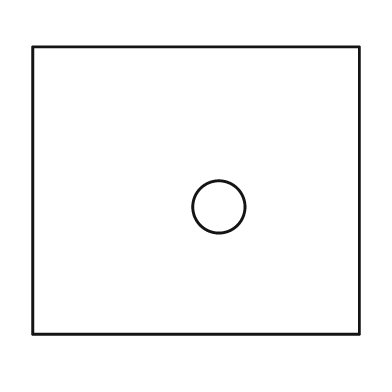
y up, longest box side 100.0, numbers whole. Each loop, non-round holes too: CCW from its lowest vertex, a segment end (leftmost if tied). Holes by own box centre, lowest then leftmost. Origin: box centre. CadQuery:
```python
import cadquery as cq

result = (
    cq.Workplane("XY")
    .moveTo(-50.0, -44.0)
    .lineTo(50.0, -44.0)
    .lineTo(50.0, 44.0)
    .lineTo(-50.0, 44.0)
    .close()
    .moveTo(7.0, -5.0)
    .circle(8.0)
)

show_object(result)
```